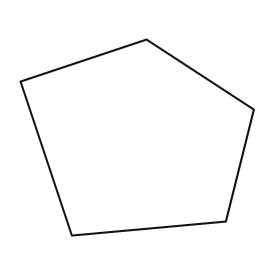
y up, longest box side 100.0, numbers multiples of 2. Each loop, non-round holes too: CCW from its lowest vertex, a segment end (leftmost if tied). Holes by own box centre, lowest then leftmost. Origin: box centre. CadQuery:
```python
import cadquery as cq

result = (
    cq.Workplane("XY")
    .moveTo(-28.0, -42.0)
    .lineTo(38.0, -36.0)
    .lineTo(50.0, 12.0)
    .lineTo(4.0, 42.0)
    .lineTo(-50.0, 24.0)
    .close()
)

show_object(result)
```